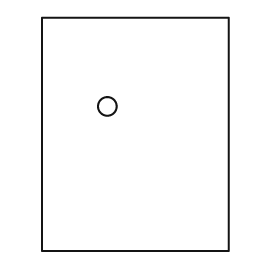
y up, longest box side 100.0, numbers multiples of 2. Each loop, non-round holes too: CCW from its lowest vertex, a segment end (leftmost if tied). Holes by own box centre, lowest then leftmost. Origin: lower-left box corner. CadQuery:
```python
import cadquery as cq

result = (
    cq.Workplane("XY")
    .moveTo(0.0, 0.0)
    .lineTo(80.0, 0.0)
    .lineTo(80.0, 100.0)
    .lineTo(0.0, 100.0)
    .close()
    .moveTo(28.0, 62.0)
    .circle(4.0)
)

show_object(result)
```